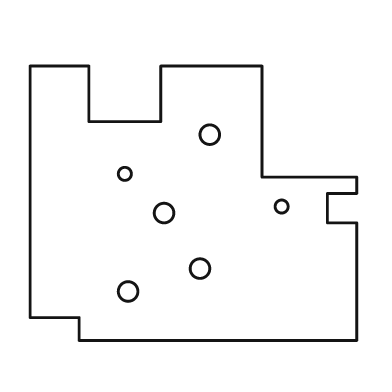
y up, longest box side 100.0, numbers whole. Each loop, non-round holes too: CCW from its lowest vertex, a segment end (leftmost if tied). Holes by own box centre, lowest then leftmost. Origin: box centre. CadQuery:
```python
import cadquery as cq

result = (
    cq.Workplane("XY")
    .moveTo(-35.0, -42.0)
    .lineTo(50.0, -42.0)
    .lineTo(50.0, -6.0)
    .lineTo(41.0, -6.0)
    .lineTo(41.0, 3.0)
    .lineTo(50.0, 3.0)
    .lineTo(50.0, 8.0)
    .lineTo(21.0, 8.0)
    .lineTo(21.0, 42.0)
    .lineTo(-10.0, 42.0)
    .lineTo(-10.0, 25.0)
    .lineTo(-32.0, 25.0)
    .lineTo(-32.0, 42.0)
    .lineTo(-50.0, 42.0)
    .lineTo(-50.0, -35.0)
    .lineTo(-35.0, -35.0)
    .close()
    .moveTo(-20.0, -27.0)
    .circle(3.0)
    .moveTo(2.0, -20.0)
    .circle(3.0)
    .moveTo(-9.0, -3.0)
    .circle(3.0)
    .moveTo(27.0, -1.0)
    .circle(2.0)
    .moveTo(-21.0, 9.0)
    .circle(2.0)
    .moveTo(5.0, 21.0)
    .circle(3.0)
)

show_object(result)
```